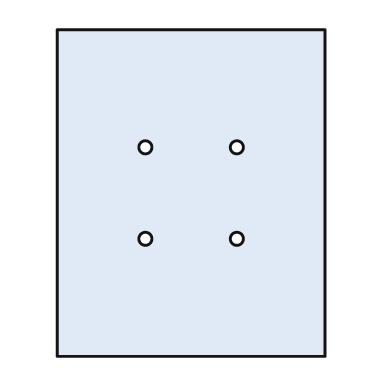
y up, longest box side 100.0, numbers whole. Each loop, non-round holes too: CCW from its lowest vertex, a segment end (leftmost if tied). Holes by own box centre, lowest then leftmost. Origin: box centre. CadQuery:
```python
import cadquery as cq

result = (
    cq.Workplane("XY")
    .moveTo(-41.0, -50.0)
    .lineTo(41.0, -50.0)
    .lineTo(41.0, 50.0)
    .lineTo(-41.0, 50.0)
    .close()
    .moveTo(-14.0, -14.0)
    .circle(2.0)
    .moveTo(14.0, -14.0)
    .circle(2.0)
    .moveTo(-14.0, 14.0)
    .circle(2.0)
    .moveTo(14.0, 14.0)
    .circle(2.0)
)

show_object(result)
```